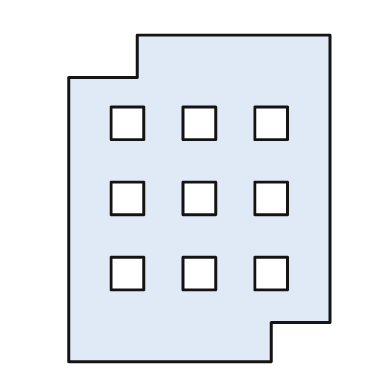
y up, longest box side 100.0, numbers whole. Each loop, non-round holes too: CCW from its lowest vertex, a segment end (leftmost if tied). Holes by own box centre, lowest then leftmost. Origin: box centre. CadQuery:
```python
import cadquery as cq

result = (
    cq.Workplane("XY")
    .moveTo(-40.0, -50.0)
    .lineTo(22.0, -50.0)
    .lineTo(22.0, -38.0)
    .lineTo(40.0, -38.0)
    .lineTo(40.0, 50.0)
    .lineTo(-19.0, 50.0)
    .lineTo(-19.0, 37.0)
    .lineTo(-40.0, 37.0)
    .close()
    .moveTo(-27.0, -28.0)
    .lineTo(-17.0, -28.0)
    .lineTo(-17.0, -18.0)
    .lineTo(-27.0, -18.0)
    .close()
    .moveTo(-5.0, -28.0)
    .lineTo(5.0, -28.0)
    .lineTo(5.0, -18.0)
    .lineTo(-5.0, -18.0)
    .close()
    .moveTo(17.0, -28.0)
    .lineTo(27.0, -28.0)
    .lineTo(27.0, -18.0)
    .lineTo(17.0, -18.0)
    .close()
    .moveTo(-27.0, -5.0)
    .lineTo(-17.0, -5.0)
    .lineTo(-17.0, 5.0)
    .lineTo(-27.0, 5.0)
    .close()
    .moveTo(-5.0, -5.0)
    .lineTo(5.0, -5.0)
    .lineTo(5.0, 5.0)
    .lineTo(-5.0, 5.0)
    .close()
    .moveTo(17.0, -5.0)
    .lineTo(27.0, -5.0)
    .lineTo(27.0, 5.0)
    .lineTo(17.0, 5.0)
    .close()
    .moveTo(-27.0, 18.0)
    .lineTo(-17.0, 18.0)
    .lineTo(-17.0, 28.0)
    .lineTo(-27.0, 28.0)
    .close()
    .moveTo(-5.0, 18.0)
    .lineTo(5.0, 18.0)
    .lineTo(5.0, 28.0)
    .lineTo(-5.0, 28.0)
    .close()
    .moveTo(17.0, 18.0)
    .lineTo(27.0, 18.0)
    .lineTo(27.0, 28.0)
    .lineTo(17.0, 28.0)
    .close()
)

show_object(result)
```